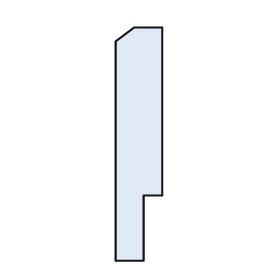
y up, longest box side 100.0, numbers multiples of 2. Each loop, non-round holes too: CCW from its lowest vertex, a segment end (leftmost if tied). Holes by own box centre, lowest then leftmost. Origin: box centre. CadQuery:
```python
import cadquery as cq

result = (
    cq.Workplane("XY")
    .moveTo(-10.0, -50.0)
    .lineTo(2.0, -50.0)
    .lineTo(2.0, -22.0)
    .lineTo(10.0, -22.0)
    .lineTo(10.0, 50.0)
    .lineTo(-2.0, 50.0)
    .lineTo(-10.0, 44.0)
    .close()
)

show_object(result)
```